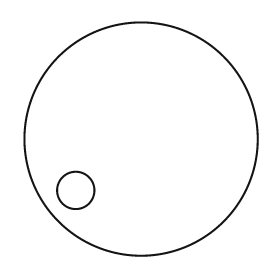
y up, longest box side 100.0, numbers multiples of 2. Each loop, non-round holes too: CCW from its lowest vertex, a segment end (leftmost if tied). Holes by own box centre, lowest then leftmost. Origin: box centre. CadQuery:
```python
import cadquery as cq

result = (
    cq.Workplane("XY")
    .moveTo(0.0, 0.0)
    .circle(50.0)
    .moveTo(-28.0, -22.0)
    .circle(8.0)
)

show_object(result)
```